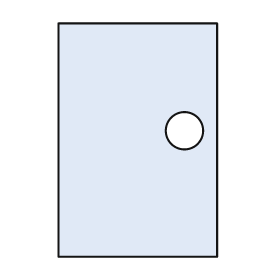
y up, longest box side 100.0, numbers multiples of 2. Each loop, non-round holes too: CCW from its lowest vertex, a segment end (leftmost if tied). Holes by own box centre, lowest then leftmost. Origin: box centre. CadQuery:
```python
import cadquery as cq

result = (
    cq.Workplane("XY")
    .moveTo(-34.0, -50.0)
    .lineTo(34.0, -50.0)
    .lineTo(34.0, 50.0)
    .lineTo(-34.0, 50.0)
    .close()
    .moveTo(20.0, 4.0)
    .circle(8.0)
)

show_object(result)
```